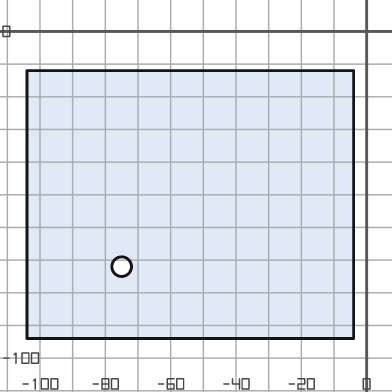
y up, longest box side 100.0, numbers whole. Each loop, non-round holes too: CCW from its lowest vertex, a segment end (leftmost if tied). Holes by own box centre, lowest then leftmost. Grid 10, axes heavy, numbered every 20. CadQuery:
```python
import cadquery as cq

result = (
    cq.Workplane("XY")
    .moveTo(-104.0, -94.0)
    .lineTo(-4.0, -94.0)
    .lineTo(-4.0, -12.0)
    .lineTo(-104.0, -12.0)
    .close()
    .moveTo(-75.0, -72.0)
    .circle(3.0)
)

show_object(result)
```